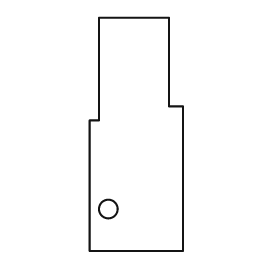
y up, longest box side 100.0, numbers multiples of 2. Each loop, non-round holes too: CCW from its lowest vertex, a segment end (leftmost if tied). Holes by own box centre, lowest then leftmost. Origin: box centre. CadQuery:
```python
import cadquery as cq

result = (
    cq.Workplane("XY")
    .moveTo(-20.0, -50.0)
    .lineTo(20.0, -50.0)
    .lineTo(20.0, 12.0)
    .lineTo(14.0, 12.0)
    .lineTo(14.0, 50.0)
    .lineTo(-16.0, 50.0)
    .lineTo(-16.0, 6.0)
    .lineTo(-20.0, 6.0)
    .close()
    .moveTo(-12.0, -32.0)
    .circle(4.0)
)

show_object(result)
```